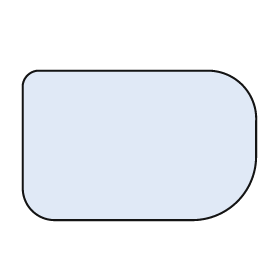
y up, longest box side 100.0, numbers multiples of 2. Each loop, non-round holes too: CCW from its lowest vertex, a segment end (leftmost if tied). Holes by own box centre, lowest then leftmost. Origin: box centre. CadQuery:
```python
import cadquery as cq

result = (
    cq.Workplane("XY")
    .moveTo(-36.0, -32.0)
    .lineTo(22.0, -32.0)
    .threePointArc((42.0, -24.0), (50.0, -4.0))
    .lineTo(50.0, 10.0)
    .threePointArc((44.0, 26.0), (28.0, 32.0))
    .lineTo(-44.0, 32.0)
    .threePointArc((-48.0, 30.0), (-50.0, 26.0))
    .lineTo(-50.0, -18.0)
    .threePointArc((-46.0, -28.0), (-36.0, -32.0))
    .close()
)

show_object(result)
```